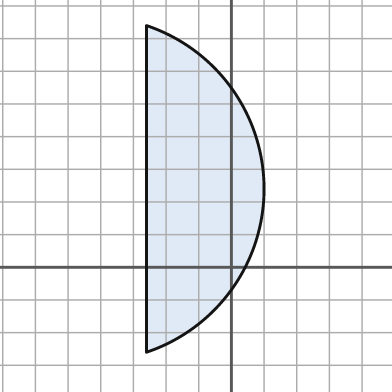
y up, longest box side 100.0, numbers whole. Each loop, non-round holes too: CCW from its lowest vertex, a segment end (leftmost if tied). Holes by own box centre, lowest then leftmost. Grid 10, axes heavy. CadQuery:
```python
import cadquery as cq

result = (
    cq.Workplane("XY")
    .moveTo(-26.0, -26.0)
    .threePointArc((10.0, 24.0), (-26.0, 74.0))
    .close()
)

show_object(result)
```